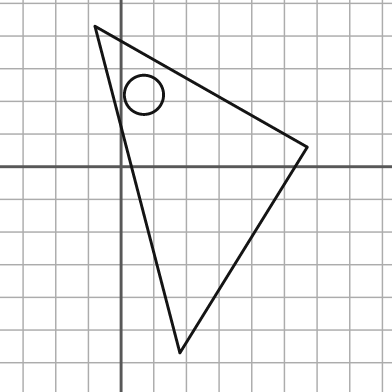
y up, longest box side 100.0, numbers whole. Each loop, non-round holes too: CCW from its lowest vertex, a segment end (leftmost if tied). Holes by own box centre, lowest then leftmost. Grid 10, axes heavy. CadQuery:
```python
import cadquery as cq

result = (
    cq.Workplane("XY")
    .moveTo(18.0, -57.0)
    .lineTo(57.0, 6.0)
    .lineTo(-8.0, 43.0)
    .close()
    .moveTo(7.0, 22.0)
    .circle(6.0)
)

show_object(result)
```